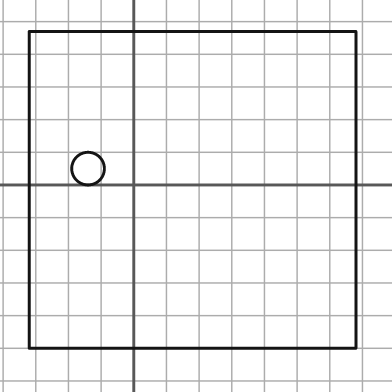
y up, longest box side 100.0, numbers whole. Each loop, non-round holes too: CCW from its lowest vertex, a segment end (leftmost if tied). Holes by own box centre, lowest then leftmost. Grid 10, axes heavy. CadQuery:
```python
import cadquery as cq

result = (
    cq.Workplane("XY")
    .moveTo(-32.0, -50.0)
    .lineTo(68.0, -50.0)
    .lineTo(68.0, 47.0)
    .lineTo(-32.0, 47.0)
    .close()
    .moveTo(-14.0, 5.0)
    .circle(5.0)
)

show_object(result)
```